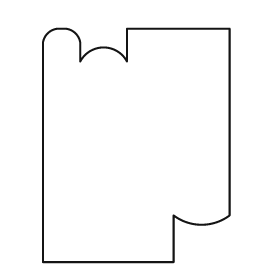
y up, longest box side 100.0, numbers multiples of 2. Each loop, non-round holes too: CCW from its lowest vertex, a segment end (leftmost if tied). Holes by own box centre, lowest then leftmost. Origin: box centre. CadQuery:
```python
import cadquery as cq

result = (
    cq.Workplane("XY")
    .moveTo(-40.0, -50.0)
    .lineTo(16.0, -50.0)
    .lineTo(16.0, -30.0)
    .threePointArc((28.0, -34.0), (40.0, -30.0))
    .lineTo(40.0, 50.0)
    .lineTo(-4.0, 50.0)
    .lineTo(-4.0, 36.0)
    .threePointArc((-14.0, 42.0), (-24.0, 36.0))
    .lineTo(-24.0, 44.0)
    .threePointArc((-26.0, 48.0), (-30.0, 50.0))
    .lineTo(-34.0, 50.0)
    .threePointArc((-38.0, 48.0), (-40.0, 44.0))
    .close()
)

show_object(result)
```